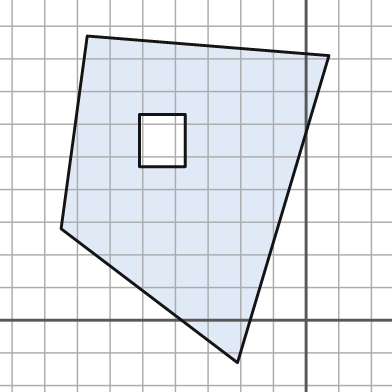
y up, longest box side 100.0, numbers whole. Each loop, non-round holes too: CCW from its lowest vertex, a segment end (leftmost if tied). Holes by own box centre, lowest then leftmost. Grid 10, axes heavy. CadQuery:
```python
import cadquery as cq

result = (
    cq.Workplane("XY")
    .moveTo(-21.0, -13.0)
    .lineTo(7.0, 81.0)
    .lineTo(-67.0, 87.0)
    .lineTo(-75.0, 28.0)
    .close()
    .moveTo(-51.0, 47.0)
    .lineTo(-37.0, 47.0)
    .lineTo(-37.0, 63.0)
    .lineTo(-51.0, 63.0)
    .close()
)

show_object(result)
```